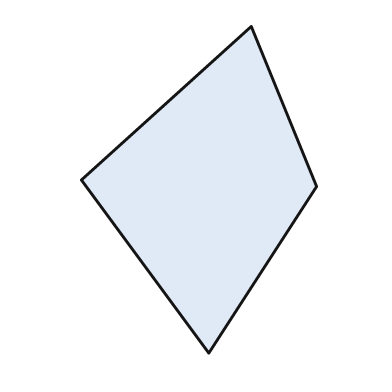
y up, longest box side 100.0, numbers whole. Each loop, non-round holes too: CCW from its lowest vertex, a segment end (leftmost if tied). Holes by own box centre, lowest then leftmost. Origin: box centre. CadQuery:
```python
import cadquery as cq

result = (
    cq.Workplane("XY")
    .moveTo(3.0, -50.0)
    .lineTo(36.0, 1.0)
    .lineTo(16.0, 50.0)
    .lineTo(-36.0, 3.0)
    .close()
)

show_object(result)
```